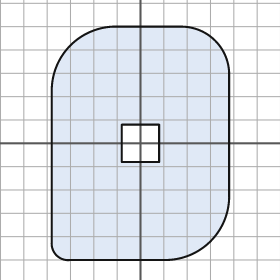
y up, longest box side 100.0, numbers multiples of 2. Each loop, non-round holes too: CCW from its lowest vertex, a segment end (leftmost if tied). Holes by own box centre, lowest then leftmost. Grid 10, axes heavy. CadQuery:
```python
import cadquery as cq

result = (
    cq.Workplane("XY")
    .moveTo(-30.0, -50.0)
    .lineTo(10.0, -50.0)
    .threePointArc((30.0, -42.0), (38.0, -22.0))
    .lineTo(38.0, 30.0)
    .threePointArc((32.0, 44.0), (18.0, 50.0))
    .lineTo(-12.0, 50.0)
    .threePointArc((-30.0, 42.0), (-38.0, 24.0))
    .lineTo(-38.0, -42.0)
    .threePointArc((-36.0, -48.0), (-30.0, -50.0))
    .close()
    .moveTo(-8.0, -8.0)
    .lineTo(8.0, -8.0)
    .lineTo(8.0, 8.0)
    .lineTo(-8.0, 8.0)
    .close()
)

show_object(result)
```